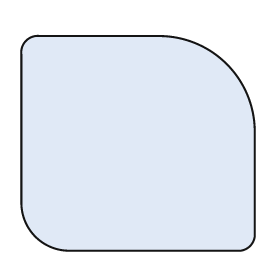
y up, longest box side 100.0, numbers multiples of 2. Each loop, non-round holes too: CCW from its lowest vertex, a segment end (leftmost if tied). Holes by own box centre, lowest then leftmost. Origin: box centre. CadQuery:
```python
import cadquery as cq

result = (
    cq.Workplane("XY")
    .moveTo(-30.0, -46.0)
    .lineTo(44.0, -46.0)
    .threePointArc((48.0, -44.0), (50.0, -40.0))
    .lineTo(50.0, 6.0)
    .threePointArc((38.0, 34.0), (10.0, 46.0))
    .lineTo(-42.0, 46.0)
    .threePointArc((-48.0, 44.0), (-50.0, 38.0))
    .lineTo(-50.0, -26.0)
    .threePointArc((-44.0, -40.0), (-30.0, -46.0))
    .close()
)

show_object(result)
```